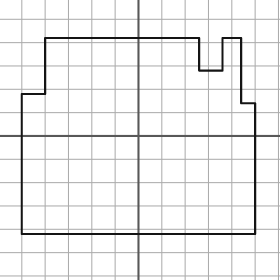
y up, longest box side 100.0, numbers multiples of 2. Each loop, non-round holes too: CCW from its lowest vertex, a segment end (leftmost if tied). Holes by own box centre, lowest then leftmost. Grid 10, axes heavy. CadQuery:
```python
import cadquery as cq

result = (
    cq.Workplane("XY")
    .moveTo(-50.0, -42.0)
    .lineTo(50.0, -42.0)
    .lineTo(50.0, 14.0)
    .lineTo(44.0, 14.0)
    .lineTo(44.0, 42.0)
    .lineTo(36.0, 42.0)
    .lineTo(36.0, 28.0)
    .lineTo(26.0, 28.0)
    .lineTo(26.0, 42.0)
    .lineTo(-40.0, 42.0)
    .lineTo(-40.0, 18.0)
    .lineTo(-50.0, 18.0)
    .close()
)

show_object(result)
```